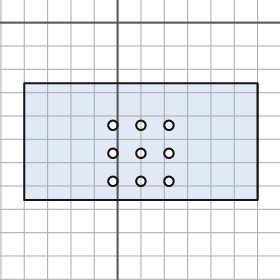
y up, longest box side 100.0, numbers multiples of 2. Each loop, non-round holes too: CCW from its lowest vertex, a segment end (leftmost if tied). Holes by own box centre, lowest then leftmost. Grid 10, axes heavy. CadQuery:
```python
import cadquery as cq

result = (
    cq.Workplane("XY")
    .moveTo(-40.0, -76.0)
    .lineTo(60.0, -76.0)
    .lineTo(60.0, -26.0)
    .lineTo(-40.0, -26.0)
    .close()
    .moveTo(-2.0, -68.0)
    .circle(2.0)
    .moveTo(10.0, -68.0)
    .circle(2.0)
    .moveTo(22.0, -68.0)
    .circle(2.0)
    .moveTo(-2.0, -56.0)
    .circle(2.0)
    .moveTo(10.0, -56.0)
    .circle(2.0)
    .moveTo(22.0, -56.0)
    .circle(2.0)
    .moveTo(-2.0, -44.0)
    .circle(2.0)
    .moveTo(10.0, -44.0)
    .circle(2.0)
    .moveTo(22.0, -44.0)
    .circle(2.0)
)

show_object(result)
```